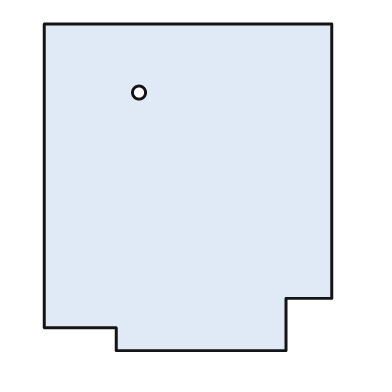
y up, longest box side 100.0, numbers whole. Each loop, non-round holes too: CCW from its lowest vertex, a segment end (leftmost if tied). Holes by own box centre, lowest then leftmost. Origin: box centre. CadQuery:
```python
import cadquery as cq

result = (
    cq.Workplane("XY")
    .moveTo(-22.0, -50.0)
    .lineTo(30.0, -50.0)
    .lineTo(30.0, -34.0)
    .lineTo(44.0, -34.0)
    .lineTo(44.0, 50.0)
    .lineTo(-44.0, 50.0)
    .lineTo(-44.0, -43.0)
    .lineTo(-22.0, -43.0)
    .close()
    .moveTo(-15.0, 29.0)
    .circle(2.0)
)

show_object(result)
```